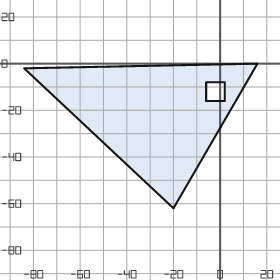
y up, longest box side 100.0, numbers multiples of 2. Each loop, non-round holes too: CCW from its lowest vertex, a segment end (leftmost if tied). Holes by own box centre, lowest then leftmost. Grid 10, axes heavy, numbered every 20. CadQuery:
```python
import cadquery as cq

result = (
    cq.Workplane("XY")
    .moveTo(-20.0, -62.0)
    .lineTo(16.0, 0.0)
    .lineTo(-84.0, -2.0)
    .close()
    .moveTo(-6.0, -16.0)
    .lineTo(2.0, -16.0)
    .lineTo(2.0, -8.0)
    .lineTo(-6.0, -8.0)
    .close()
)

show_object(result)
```